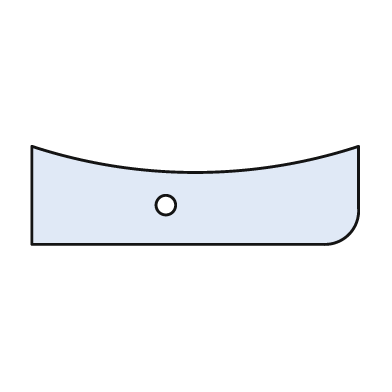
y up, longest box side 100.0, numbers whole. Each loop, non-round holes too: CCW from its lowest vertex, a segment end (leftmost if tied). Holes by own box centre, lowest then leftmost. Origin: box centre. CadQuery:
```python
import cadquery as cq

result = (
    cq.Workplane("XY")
    .moveTo(-50.0, -15.0)
    .lineTo(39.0, -15.0)
    .threePointArc((47.0, -12.0), (50.0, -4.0))
    .lineTo(50.0, 15.0)
    .threePointArc((0.0, 7.0), (-50.0, 15.0))
    .close()
    .moveTo(-9.0, -3.0)
    .circle(3.0)
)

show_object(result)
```